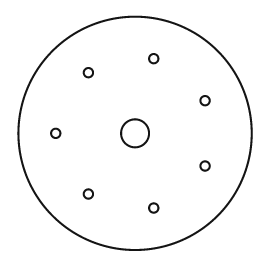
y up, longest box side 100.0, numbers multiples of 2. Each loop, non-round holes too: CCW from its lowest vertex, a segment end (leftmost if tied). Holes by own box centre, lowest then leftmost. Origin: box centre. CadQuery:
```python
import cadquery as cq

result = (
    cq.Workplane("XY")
    .moveTo(0.0, 0.0)
    .circle(50.0)
    .moveTo(8.0, -32.0)
    .circle(2.0)
    .moveTo(-20.0, -26.0)
    .circle(2.0)
    .moveTo(30.0, -14.0)
    .circle(2.0)
    .moveTo(-34.0, 0.0)
    .circle(2.0)
    .moveTo(0.0, 0.0)
    .circle(6.0)
    .moveTo(30.0, 14.0)
    .circle(2.0)
    .moveTo(-20.0, 26.0)
    .circle(2.0)
    .moveTo(8.0, 32.0)
    .circle(2.0)
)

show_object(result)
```